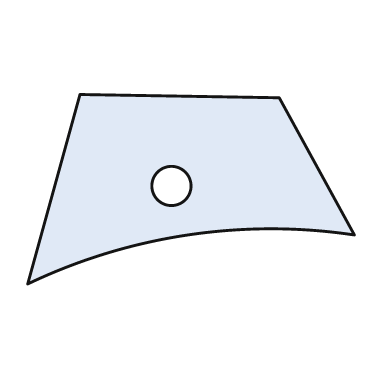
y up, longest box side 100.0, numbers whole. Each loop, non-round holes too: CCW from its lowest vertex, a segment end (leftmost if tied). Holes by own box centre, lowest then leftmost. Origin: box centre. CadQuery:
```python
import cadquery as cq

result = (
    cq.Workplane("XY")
    .moveTo(-50.0, -29.0)
    .threePointArc((-1.0, -14.0), (50.0, -14.0))
    .lineTo(27.0, 28.0)
    .lineTo(-34.0, 29.0)
    .close()
    .moveTo(-6.0, 1.0)
    .circle(6.0)
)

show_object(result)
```